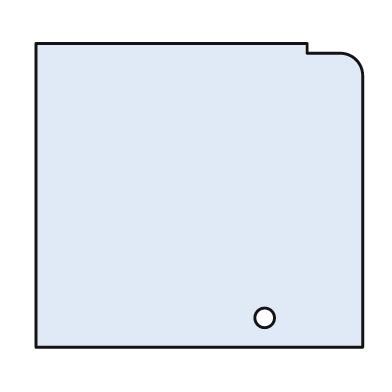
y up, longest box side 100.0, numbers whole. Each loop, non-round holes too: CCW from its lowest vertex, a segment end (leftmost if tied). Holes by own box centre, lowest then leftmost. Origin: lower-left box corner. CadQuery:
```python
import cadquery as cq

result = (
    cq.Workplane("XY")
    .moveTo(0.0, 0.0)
    .lineTo(100.0, 0.0)
    .lineTo(100.0, 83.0)
    .threePointArc((98.0, 88.0), (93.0, 90.0))
    .lineTo(83.0, 90.0)
    .lineTo(83.0, 93.0)
    .lineTo(0.0, 93.0)
    .close()
    .moveTo(70.0, 9.0)
    .circle(3.0)
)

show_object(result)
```